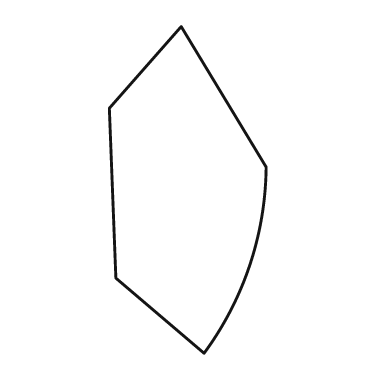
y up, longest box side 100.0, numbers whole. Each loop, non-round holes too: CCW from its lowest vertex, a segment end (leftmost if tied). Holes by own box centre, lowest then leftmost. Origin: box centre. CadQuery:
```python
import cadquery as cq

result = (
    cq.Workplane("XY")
    .moveTo(5.0, -50.0)
    .threePointArc((19.0, -23.0), (24.0, 7.0))
    .lineTo(-2.0, 50.0)
    .lineTo(-24.0, 25.0)
    .lineTo(-22.0, -27.0)
    .close()
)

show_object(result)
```